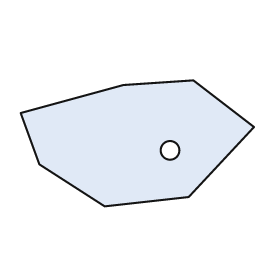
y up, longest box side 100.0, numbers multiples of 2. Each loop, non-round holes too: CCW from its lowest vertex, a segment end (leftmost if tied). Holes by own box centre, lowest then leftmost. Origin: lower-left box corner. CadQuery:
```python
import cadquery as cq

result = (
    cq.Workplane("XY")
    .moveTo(36.0, 0.0)
    .lineTo(72.0, 4.0)
    .lineTo(100.0, 34.0)
    .lineTo(74.0, 54.0)
    .lineTo(44.0, 52.0)
    .lineTo(0.0, 40.0)
    .lineTo(8.0, 18.0)
    .close()
    .moveTo(64.0, 24.0)
    .circle(4.0)
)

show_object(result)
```